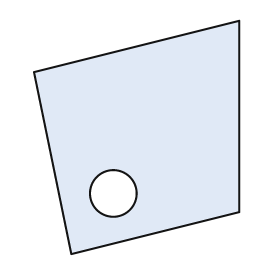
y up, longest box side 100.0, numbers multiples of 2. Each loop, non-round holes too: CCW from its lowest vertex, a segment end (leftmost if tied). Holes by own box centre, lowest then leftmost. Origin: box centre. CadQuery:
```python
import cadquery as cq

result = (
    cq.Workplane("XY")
    .moveTo(-28.0, -50.0)
    .lineTo(44.0, -32.0)
    .lineTo(44.0, 50.0)
    .lineTo(-44.0, 28.0)
    .close()
    .moveTo(-10.0, -24.0)
    .circle(10.0)
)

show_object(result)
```